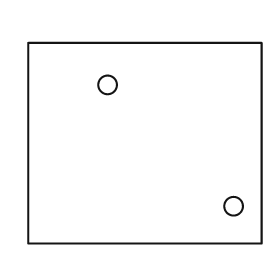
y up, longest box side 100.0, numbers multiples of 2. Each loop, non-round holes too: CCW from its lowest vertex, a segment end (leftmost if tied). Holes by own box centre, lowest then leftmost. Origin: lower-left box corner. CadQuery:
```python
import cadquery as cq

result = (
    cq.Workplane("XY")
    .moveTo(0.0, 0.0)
    .lineTo(100.0, 0.0)
    .lineTo(100.0, 86.0)
    .lineTo(0.0, 86.0)
    .close()
    .moveTo(88.0, 16.0)
    .circle(4.0)
    .moveTo(34.0, 68.0)
    .circle(4.0)
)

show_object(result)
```